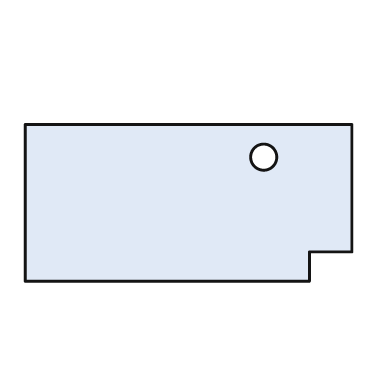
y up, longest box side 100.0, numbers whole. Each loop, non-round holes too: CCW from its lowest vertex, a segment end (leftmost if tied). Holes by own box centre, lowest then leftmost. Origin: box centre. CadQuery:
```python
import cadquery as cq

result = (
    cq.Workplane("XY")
    .moveTo(-50.0, -24.0)
    .lineTo(37.0, -24.0)
    .lineTo(37.0, -15.0)
    .lineTo(50.0, -15.0)
    .lineTo(50.0, 24.0)
    .lineTo(-50.0, 24.0)
    .close()
    .moveTo(23.0, 14.0)
    .circle(4.0)
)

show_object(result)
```